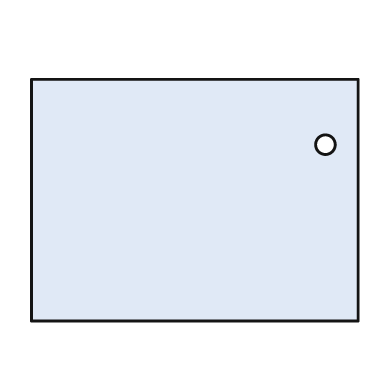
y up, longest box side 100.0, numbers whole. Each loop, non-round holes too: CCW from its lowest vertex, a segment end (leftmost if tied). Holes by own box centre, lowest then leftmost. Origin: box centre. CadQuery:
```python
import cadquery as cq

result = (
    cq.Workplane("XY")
    .moveTo(-50.0, -37.0)
    .lineTo(50.0, -37.0)
    .lineTo(50.0, 37.0)
    .lineTo(-50.0, 37.0)
    .close()
    .moveTo(40.0, 17.0)
    .circle(3.0)
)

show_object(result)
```